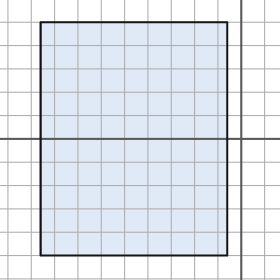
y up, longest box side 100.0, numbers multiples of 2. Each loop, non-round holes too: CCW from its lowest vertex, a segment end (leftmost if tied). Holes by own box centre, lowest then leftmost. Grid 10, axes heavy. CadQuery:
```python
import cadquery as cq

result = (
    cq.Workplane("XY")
    .moveTo(-86.0, -50.0)
    .lineTo(-6.0, -50.0)
    .lineTo(-6.0, 50.0)
    .lineTo(-86.0, 50.0)
    .close()
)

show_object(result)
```